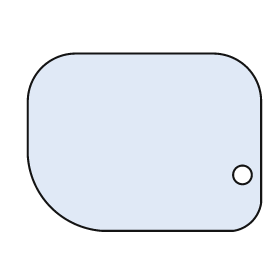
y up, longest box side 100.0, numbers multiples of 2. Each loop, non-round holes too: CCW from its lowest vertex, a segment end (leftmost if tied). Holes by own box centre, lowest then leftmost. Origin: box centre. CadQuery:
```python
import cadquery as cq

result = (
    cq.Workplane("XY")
    .moveTo(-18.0, -38.0)
    .lineTo(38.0, -38.0)
    .threePointArc((46.0, -34.0), (50.0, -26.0))
    .lineTo(50.0, 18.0)
    .threePointArc((44.0, 32.0), (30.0, 38.0))
    .lineTo(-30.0, 38.0)
    .threePointArc((-44.0, 32.0), (-50.0, 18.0))
    .lineTo(-50.0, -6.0)
    .threePointArc((-40.0, -28.0), (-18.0, -38.0))
    .close()
    .moveTo(42.0, -14.0)
    .circle(4.0)
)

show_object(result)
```